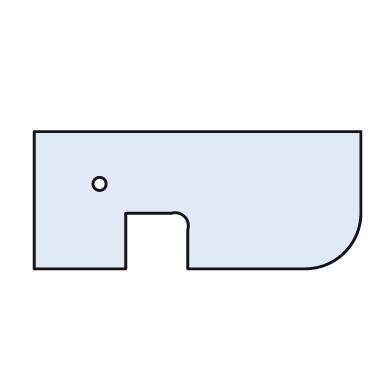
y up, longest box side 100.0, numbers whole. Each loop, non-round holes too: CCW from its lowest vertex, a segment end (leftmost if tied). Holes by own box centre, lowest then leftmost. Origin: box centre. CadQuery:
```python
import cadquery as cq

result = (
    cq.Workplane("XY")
    .moveTo(-50.0, -21.0)
    .lineTo(-22.0, -21.0)
    .lineTo(-22.0, -4.0)
    .lineTo(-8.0, -4.0)
    .threePointArc((-4.0, -5.0), (-3.0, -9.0))
    .lineTo(-3.0, -21.0)
    .lineTo(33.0, -21.0)
    .threePointArc((45.0, -16.0), (50.0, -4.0))
    .lineTo(50.0, 21.0)
    .lineTo(-50.0, 21.0)
    .close()
    .moveTo(-30.0, 5.0)
    .circle(2.0)
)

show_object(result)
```